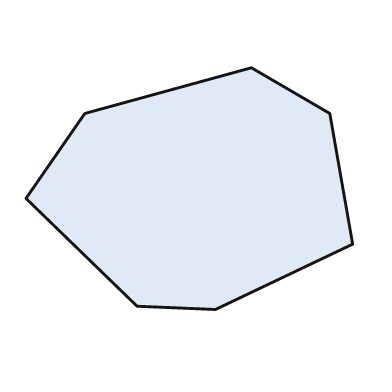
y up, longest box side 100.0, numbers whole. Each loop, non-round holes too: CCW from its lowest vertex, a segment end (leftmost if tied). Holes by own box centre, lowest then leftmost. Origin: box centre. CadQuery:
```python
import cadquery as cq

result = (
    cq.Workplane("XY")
    .moveTo(8.0, -37.0)
    .lineTo(50.0, -17.0)
    .lineTo(43.0, 23.0)
    .lineTo(19.0, 37.0)
    .lineTo(-32.0, 23.0)
    .lineTo(-50.0, -3.0)
    .lineTo(-16.0, -36.0)
    .close()
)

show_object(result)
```